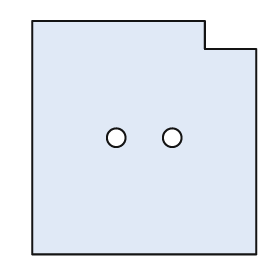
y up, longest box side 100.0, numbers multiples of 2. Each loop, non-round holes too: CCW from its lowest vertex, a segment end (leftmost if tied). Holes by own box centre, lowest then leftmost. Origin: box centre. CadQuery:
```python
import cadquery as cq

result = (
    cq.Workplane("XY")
    .moveTo(-48.0, -50.0)
    .lineTo(48.0, -50.0)
    .lineTo(48.0, 38.0)
    .lineTo(26.0, 38.0)
    .lineTo(26.0, 50.0)
    .lineTo(-48.0, 50.0)
    .close()
    .moveTo(-12.0, 0.0)
    .circle(4.0)
    .moveTo(12.0, 0.0)
    .circle(4.0)
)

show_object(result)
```